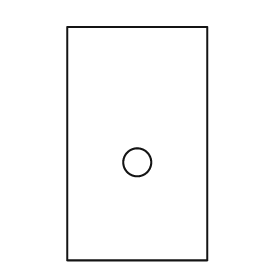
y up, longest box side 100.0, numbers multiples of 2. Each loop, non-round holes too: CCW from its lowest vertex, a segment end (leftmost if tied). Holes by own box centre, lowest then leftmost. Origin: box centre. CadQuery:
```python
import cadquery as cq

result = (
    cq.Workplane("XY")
    .moveTo(-30.0, -50.0)
    .lineTo(30.0, -50.0)
    .lineTo(30.0, 50.0)
    .lineTo(-30.0, 50.0)
    .close()
    .moveTo(0.0, -8.0)
    .circle(6.0)
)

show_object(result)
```